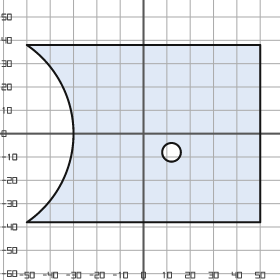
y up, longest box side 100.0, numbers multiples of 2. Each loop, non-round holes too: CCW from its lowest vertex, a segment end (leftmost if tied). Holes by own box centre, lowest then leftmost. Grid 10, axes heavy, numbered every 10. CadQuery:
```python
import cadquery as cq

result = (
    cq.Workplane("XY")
    .moveTo(-50.0, -38.0)
    .lineTo(50.0, -38.0)
    .lineTo(50.0, 38.0)
    .lineTo(-50.0, 38.0)
    .threePointArc((-30.0, 0.0), (-50.0, -38.0))
    .close()
    .moveTo(12.0, -8.0)
    .circle(4.0)
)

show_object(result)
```